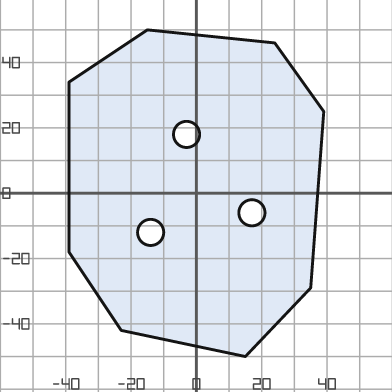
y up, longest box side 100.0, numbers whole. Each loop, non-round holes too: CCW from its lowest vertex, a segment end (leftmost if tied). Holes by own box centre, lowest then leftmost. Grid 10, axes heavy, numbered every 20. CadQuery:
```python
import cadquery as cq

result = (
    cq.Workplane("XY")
    .moveTo(15.0, -50.0)
    .lineTo(35.0, -29.0)
    .lineTo(39.0, 25.0)
    .lineTo(24.0, 46.0)
    .lineTo(-15.0, 50.0)
    .lineTo(-39.0, 34.0)
    .lineTo(-39.0, -18.0)
    .lineTo(-23.0, -42.0)
    .close()
    .moveTo(-14.0, -12.0)
    .circle(4.0)
    .moveTo(17.0, -6.0)
    .circle(4.0)
    .moveTo(-3.0, 18.0)
    .circle(4.0)
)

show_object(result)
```